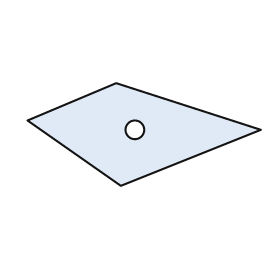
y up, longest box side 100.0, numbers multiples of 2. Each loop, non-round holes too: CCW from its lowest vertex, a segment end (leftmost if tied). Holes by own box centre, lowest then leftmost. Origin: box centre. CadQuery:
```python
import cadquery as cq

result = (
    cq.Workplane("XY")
    .moveTo(-10.0, -22.0)
    .lineTo(50.0, 2.0)
    .lineTo(-12.0, 22.0)
    .lineTo(-50.0, 6.0)
    .close()
    .moveTo(-4.0, 2.0)
    .circle(4.0)
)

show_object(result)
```